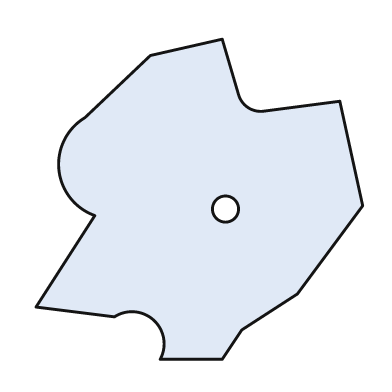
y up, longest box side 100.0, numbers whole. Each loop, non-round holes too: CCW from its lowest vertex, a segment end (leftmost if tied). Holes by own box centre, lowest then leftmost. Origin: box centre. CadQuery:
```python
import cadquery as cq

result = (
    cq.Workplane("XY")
    .moveTo(-12.0, -49.0)
    .lineTo(7.0, -49.0)
    .lineTo(13.0, -40.0)
    .lineTo(30.0, -29.0)
    .lineTo(50.0, -2.0)
    .lineTo(43.0, 30.0)
    .lineTo(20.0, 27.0)
    .threePointArc((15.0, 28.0), (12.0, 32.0))
    .lineTo(7.0, 49.0)
    .lineTo(-15.0, 44.0)
    .lineTo(-35.0, 25.0)
    .threePointArc((-43.0, 9.0), (-32.0, -5.0))
    .lineTo(-50.0, -33.0)
    .lineTo(-26.0, -36.0)
    .threePointArc((-14.0, -37.0), (-12.0, -49.0))
    .close()
    .moveTo(8.0, -3.0)
    .circle(4.0)
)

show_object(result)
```